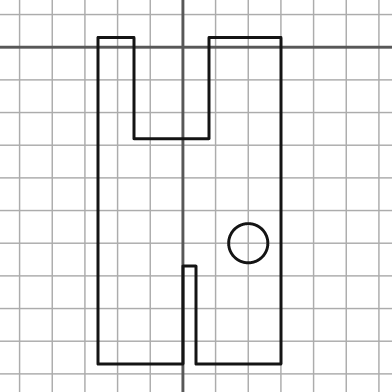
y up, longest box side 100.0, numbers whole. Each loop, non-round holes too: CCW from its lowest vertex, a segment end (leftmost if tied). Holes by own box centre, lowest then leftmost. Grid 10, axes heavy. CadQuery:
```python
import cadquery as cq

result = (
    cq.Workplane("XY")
    .moveTo(-26.0, -97.0)
    .lineTo(0.0, -97.0)
    .lineTo(0.0, -67.0)
    .lineTo(4.0, -67.0)
    .lineTo(4.0, -97.0)
    .lineTo(30.0, -97.0)
    .lineTo(30.0, 3.0)
    .lineTo(8.0, 3.0)
    .lineTo(8.0, -28.0)
    .lineTo(-15.0, -28.0)
    .lineTo(-15.0, 3.0)
    .lineTo(-26.0, 3.0)
    .close()
    .moveTo(20.0, -60.0)
    .circle(6.0)
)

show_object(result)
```